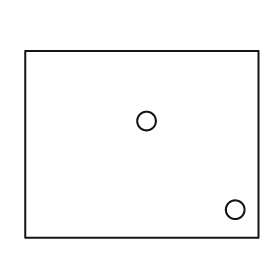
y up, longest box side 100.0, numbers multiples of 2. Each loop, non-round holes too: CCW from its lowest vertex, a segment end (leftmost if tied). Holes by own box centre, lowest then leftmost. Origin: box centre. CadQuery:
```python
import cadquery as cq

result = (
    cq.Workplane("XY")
    .moveTo(-50.0, -40.0)
    .lineTo(50.0, -40.0)
    .lineTo(50.0, 40.0)
    .lineTo(-50.0, 40.0)
    .close()
    .moveTo(40.0, -28.0)
    .circle(4.0)
    .moveTo(2.0, 10.0)
    .circle(4.0)
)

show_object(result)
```